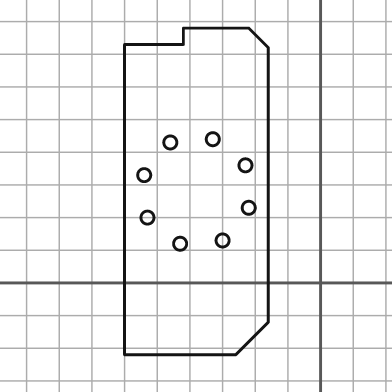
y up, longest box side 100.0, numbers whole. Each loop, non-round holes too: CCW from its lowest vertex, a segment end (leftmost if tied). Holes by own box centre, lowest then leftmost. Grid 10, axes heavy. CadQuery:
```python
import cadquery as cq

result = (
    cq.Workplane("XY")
    .moveTo(-60.0, -22.0)
    .lineTo(-26.0, -22.0)
    .lineTo(-16.0, -12.0)
    .lineTo(-16.0, 72.0)
    .lineTo(-22.0, 78.0)
    .lineTo(-42.0, 78.0)
    .lineTo(-42.0, 73.0)
    .lineTo(-60.0, 73.0)
    .close()
    .moveTo(-43.0, 12.0)
    .circle(2.0)
    .moveTo(-30.0, 13.0)
    .circle(2.0)
    .moveTo(-53.0, 20.0)
    .circle(2.0)
    .moveTo(-22.0, 23.0)
    .circle(2.0)
    .moveTo(-54.0, 33.0)
    .circle(2.0)
    .moveTo(-23.0, 36.0)
    .circle(2.0)
    .moveTo(-46.0, 43.0)
    .circle(2.0)
    .moveTo(-33.0, 44.0)
    .circle(2.0)
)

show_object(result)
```